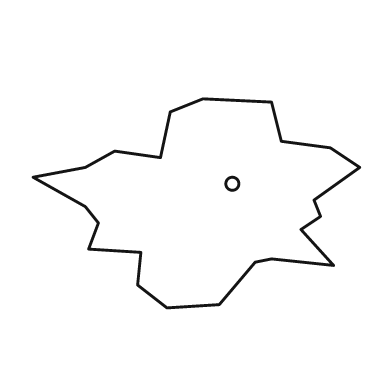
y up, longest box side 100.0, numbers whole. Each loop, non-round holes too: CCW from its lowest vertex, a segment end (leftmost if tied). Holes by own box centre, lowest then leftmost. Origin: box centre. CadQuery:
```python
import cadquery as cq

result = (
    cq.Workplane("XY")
    .moveTo(-9.0, -32.0)
    .lineTo(7.0, -31.0)
    .lineTo(18.0, -18.0)
    .lineTo(23.0, -17.0)
    .lineTo(42.0, -19.0)
    .lineTo(32.0, -8.0)
    .lineTo(38.0, -4.0)
    .lineTo(36.0, 1.0)
    .lineTo(50.0, 11.0)
    .lineTo(41.0, 17.0)
    .lineTo(26.0, 19.0)
    .lineTo(23.0, 31.0)
    .lineTo(2.0, 32.0)
    .lineTo(-8.0, 28.0)
    .lineTo(-11.0, 14.0)
    .lineTo(-25.0, 16.0)
    .lineTo(-34.0, 11.0)
    .lineTo(-50.0, 8.0)
    .lineTo(-34.0, -1.0)
    .lineTo(-30.0, -6.0)
    .lineTo(-33.0, -14.0)
    .lineTo(-17.0, -15.0)
    .lineTo(-18.0, -25.0)
    .close()
    .moveTo(11.0, 6.0)
    .circle(2.0)
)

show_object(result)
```